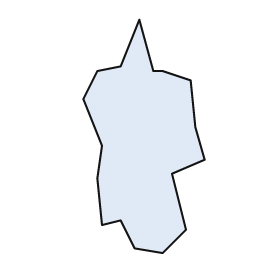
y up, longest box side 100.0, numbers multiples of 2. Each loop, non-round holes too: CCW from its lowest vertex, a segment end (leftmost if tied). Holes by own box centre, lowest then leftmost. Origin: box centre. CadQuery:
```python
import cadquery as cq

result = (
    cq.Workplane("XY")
    .moveTo(8.0, -50.0)
    .lineTo(18.0, -40.0)
    .lineTo(12.0, -16.0)
    .lineTo(26.0, -10.0)
    .lineTo(22.0, 4.0)
    .lineTo(20.0, 24.0)
    .lineTo(8.0, 28.0)
    .lineTo(4.0, 28.0)
    .lineTo(-2.0, 50.0)
    .lineTo(-10.0, 30.0)
    .lineTo(-20.0, 28.0)
    .lineTo(-26.0, 16.0)
    .lineTo(-18.0, -4.0)
    .lineTo(-20.0, -18.0)
    .lineTo(-18.0, -38.0)
    .lineTo(-10.0, -36.0)
    .lineTo(-4.0, -48.0)
    .close()
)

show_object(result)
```